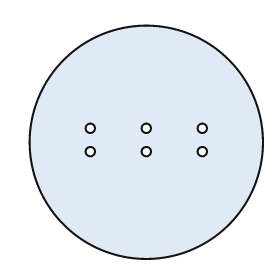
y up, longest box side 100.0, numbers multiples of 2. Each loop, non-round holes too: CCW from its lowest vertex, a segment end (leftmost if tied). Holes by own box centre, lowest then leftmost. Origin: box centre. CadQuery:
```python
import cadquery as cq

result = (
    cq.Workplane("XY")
    .moveTo(0.0, 0.0)
    .circle(50.0)
    .moveTo(-24.0, -4.0)
    .circle(2.0)
    .moveTo(0.0, -4.0)
    .circle(2.0)
    .moveTo(24.0, -4.0)
    .circle(2.0)
    .moveTo(-24.0, 6.0)
    .circle(2.0)
    .moveTo(0.0, 6.0)
    .circle(2.0)
    .moveTo(24.0, 6.0)
    .circle(2.0)
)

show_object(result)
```